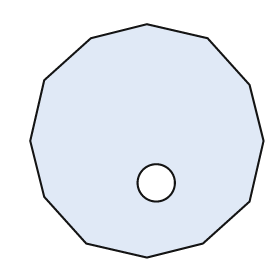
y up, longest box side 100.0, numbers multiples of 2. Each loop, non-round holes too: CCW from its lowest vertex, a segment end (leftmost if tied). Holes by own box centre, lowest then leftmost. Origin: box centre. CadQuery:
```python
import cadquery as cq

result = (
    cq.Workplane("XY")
    .moveTo(0.0, -50.0)
    .lineTo(24.0, -44.0)
    .lineTo(44.0, -26.0)
    .lineTo(50.0, 0.0)
    .lineTo(44.0, 24.0)
    .lineTo(26.0, 44.0)
    .lineTo(0.0, 50.0)
    .lineTo(-24.0, 44.0)
    .lineTo(-44.0, 26.0)
    .lineTo(-50.0, 0.0)
    .lineTo(-44.0, -24.0)
    .lineTo(-26.0, -44.0)
    .close()
    .moveTo(4.0, -18.0)
    .circle(8.0)
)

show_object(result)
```